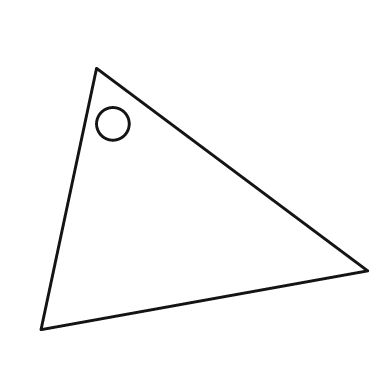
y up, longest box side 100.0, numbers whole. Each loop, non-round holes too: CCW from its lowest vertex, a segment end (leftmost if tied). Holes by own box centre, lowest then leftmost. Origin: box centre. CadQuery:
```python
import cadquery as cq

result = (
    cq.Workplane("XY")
    .moveTo(-50.0, -40.0)
    .lineTo(50.0, -22.0)
    .lineTo(-33.0, 40.0)
    .close()
    .moveTo(-28.0, 23.0)
    .circle(5.0)
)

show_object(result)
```